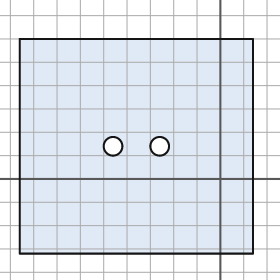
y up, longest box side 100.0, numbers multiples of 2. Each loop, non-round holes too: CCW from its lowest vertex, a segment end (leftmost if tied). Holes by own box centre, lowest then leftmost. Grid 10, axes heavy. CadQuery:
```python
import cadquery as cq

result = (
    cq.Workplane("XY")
    .moveTo(-86.0, -32.0)
    .lineTo(14.0, -32.0)
    .lineTo(14.0, 60.0)
    .lineTo(-86.0, 60.0)
    .close()
    .moveTo(-46.0, 14.0)
    .circle(4.0)
    .moveTo(-26.0, 14.0)
    .circle(4.0)
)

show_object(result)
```